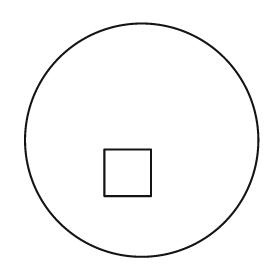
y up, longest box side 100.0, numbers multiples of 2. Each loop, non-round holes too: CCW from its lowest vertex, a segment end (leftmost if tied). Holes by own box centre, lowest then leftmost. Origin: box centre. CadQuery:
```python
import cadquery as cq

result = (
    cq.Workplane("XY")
    .moveTo(0.0, 0.0)
    .circle(50.0)
    .moveTo(-16.0, -24.0)
    .lineTo(4.0, -24.0)
    .lineTo(4.0, -4.0)
    .lineTo(-16.0, -4.0)
    .close()
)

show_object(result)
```